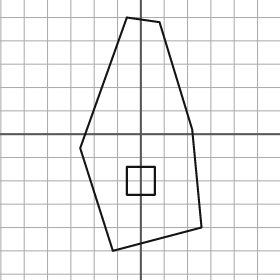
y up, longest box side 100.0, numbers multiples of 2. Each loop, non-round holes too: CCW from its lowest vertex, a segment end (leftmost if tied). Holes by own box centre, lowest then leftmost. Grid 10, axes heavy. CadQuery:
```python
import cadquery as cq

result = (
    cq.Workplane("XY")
    .moveTo(-12.0, -50.0)
    .lineTo(26.0, -40.0)
    .lineTo(22.0, 2.0)
    .lineTo(8.0, 48.0)
    .lineTo(-6.0, 50.0)
    .lineTo(-26.0, -6.0)
    .close()
    .moveTo(-6.0, -26.0)
    .lineTo(6.0, -26.0)
    .lineTo(6.0, -14.0)
    .lineTo(-6.0, -14.0)
    .close()
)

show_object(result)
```